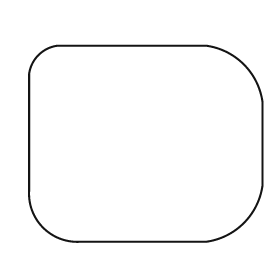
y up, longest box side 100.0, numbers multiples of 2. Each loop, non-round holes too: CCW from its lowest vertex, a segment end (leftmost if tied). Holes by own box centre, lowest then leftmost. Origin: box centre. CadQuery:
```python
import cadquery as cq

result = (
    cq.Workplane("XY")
    .moveTo(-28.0, -42.0)
    .lineTo(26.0, -42.0)
    .threePointArc((42.0, -34.0), (50.0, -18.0))
    .lineTo(50.0, 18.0)
    .threePointArc((42.0, 34.0), (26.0, 42.0))
    .lineTo(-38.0, 42.0)
    .threePointArc((-46.0, 38.0), (-50.0, 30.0))
    .lineTo(-50.0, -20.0)
    .threePointArc((-44.0, -36.0), (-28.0, -42.0))
    .close()
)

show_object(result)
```